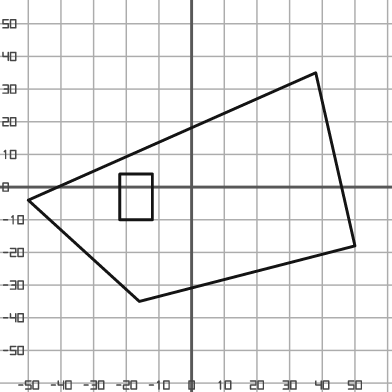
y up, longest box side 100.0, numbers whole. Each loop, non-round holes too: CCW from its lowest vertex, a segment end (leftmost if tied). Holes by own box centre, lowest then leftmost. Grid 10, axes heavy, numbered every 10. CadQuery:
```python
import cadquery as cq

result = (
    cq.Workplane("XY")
    .moveTo(-16.0, -35.0)
    .lineTo(50.0, -18.0)
    .lineTo(38.0, 35.0)
    .lineTo(-50.0, -4.0)
    .close()
    .moveTo(-22.0, -10.0)
    .lineTo(-12.0, -10.0)
    .lineTo(-12.0, 4.0)
    .lineTo(-22.0, 4.0)
    .close()
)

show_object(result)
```